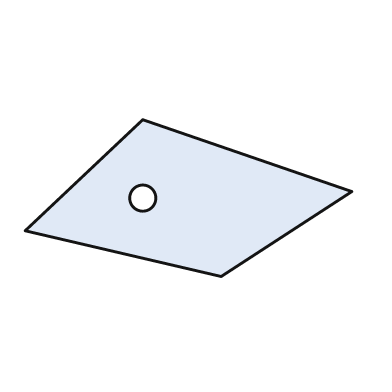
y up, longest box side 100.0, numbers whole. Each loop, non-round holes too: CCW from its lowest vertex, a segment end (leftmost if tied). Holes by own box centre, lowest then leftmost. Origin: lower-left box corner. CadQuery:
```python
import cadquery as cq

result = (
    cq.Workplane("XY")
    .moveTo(60.0, 0.0)
    .lineTo(100.0, 26.0)
    .lineTo(36.0, 48.0)
    .lineTo(0.0, 14.0)
    .close()
    .moveTo(36.0, 24.0)
    .circle(4.0)
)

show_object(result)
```